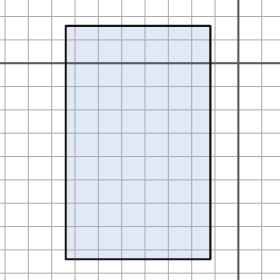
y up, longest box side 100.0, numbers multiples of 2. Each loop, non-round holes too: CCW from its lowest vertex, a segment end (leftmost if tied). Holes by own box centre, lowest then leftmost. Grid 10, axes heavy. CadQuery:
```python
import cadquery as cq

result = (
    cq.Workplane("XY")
    .moveTo(-74.0, -84.0)
    .lineTo(-12.0, -84.0)
    .lineTo(-12.0, 16.0)
    .lineTo(-74.0, 16.0)
    .close()
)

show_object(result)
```